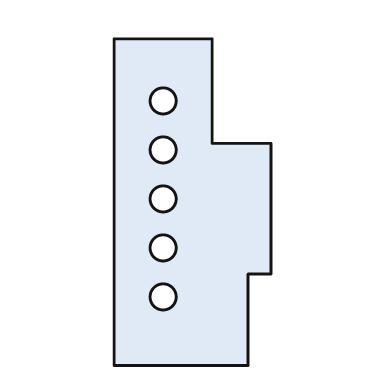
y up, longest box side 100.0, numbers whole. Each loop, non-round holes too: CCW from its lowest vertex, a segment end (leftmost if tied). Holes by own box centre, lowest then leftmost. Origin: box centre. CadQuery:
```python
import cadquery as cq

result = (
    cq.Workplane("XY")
    .moveTo(-24.0, -50.0)
    .lineTo(17.0, -50.0)
    .lineTo(17.0, -22.0)
    .lineTo(24.0, -22.0)
    .lineTo(24.0, 18.0)
    .lineTo(6.0, 18.0)
    .lineTo(6.0, 50.0)
    .lineTo(-24.0, 50.0)
    .close()
    .moveTo(-9.0, -29.0)
    .circle(4.0)
    .moveTo(-9.0, -14.0)
    .circle(4.0)
    .moveTo(-9.0, 1.0)
    .circle(4.0)
    .moveTo(-9.0, 16.0)
    .circle(4.0)
    .moveTo(-9.0, 31.0)
    .circle(4.0)
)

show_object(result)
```